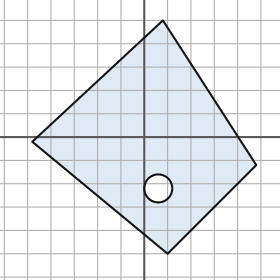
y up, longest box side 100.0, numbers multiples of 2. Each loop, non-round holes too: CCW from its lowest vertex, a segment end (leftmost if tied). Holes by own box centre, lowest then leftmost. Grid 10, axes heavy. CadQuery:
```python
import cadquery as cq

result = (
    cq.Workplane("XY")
    .moveTo(10.0, -50.0)
    .lineTo(48.0, -12.0)
    .lineTo(8.0, 50.0)
    .lineTo(-48.0, -2.0)
    .close()
    .moveTo(6.0, -22.0)
    .circle(6.0)
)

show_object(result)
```